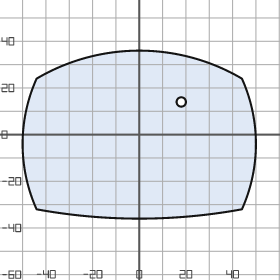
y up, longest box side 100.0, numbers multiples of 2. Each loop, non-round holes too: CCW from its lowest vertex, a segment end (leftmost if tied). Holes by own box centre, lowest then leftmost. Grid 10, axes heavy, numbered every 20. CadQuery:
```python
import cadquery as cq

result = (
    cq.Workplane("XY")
    .moveTo(-44.0, -32.0)
    .threePointArc((0.0, -36.0), (44.0, -32.0))
    .threePointArc((50.0, -4.0), (44.0, 24.0))
    .threePointArc((0.0, 36.0), (-44.0, 24.0))
    .threePointArc((-50.0, -4.0), (-44.0, -32.0))
    .close()
    .moveTo(18.0, 14.0)
    .circle(2.0)
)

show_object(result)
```